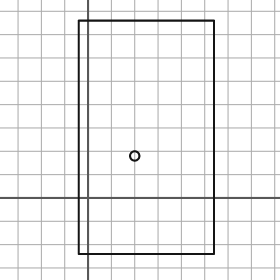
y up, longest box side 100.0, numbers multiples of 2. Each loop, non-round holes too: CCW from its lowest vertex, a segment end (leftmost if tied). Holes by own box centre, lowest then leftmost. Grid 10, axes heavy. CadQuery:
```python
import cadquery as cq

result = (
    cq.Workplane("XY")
    .moveTo(-4.0, -24.0)
    .lineTo(54.0, -24.0)
    .lineTo(54.0, 76.0)
    .lineTo(-4.0, 76.0)
    .close()
    .moveTo(20.0, 18.0)
    .circle(2.0)
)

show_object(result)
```